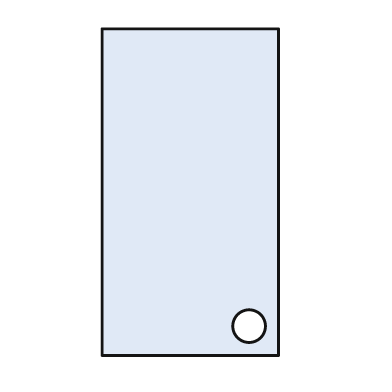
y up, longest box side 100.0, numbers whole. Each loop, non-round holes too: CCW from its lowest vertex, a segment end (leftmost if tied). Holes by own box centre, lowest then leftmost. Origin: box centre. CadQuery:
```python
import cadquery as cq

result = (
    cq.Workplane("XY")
    .moveTo(-27.0, -50.0)
    .lineTo(27.0, -50.0)
    .lineTo(27.0, 50.0)
    .lineTo(-27.0, 50.0)
    .close()
    .moveTo(18.0, -41.0)
    .circle(5.0)
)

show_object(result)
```